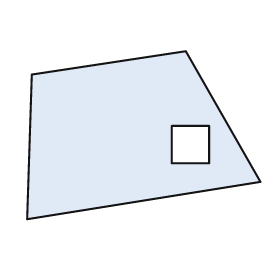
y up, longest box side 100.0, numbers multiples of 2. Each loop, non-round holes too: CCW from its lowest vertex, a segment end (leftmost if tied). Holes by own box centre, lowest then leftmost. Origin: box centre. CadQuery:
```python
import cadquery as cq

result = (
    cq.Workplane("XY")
    .moveTo(-50.0, -36.0)
    .lineTo(50.0, -20.0)
    .lineTo(18.0, 36.0)
    .lineTo(-48.0, 26.0)
    .close()
    .moveTo(12.0, -12.0)
    .lineTo(28.0, -12.0)
    .lineTo(28.0, 4.0)
    .lineTo(12.0, 4.0)
    .close()
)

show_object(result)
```